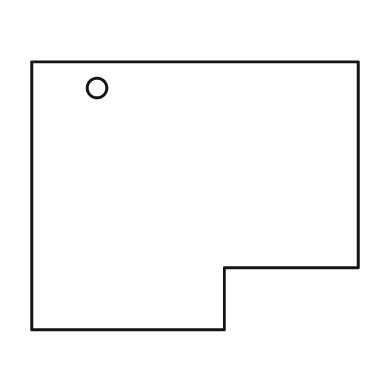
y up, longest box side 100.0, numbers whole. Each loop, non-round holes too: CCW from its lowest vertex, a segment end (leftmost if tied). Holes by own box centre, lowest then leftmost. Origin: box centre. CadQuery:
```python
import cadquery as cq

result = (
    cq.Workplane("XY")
    .moveTo(-50.0, -41.0)
    .lineTo(9.0, -41.0)
    .lineTo(9.0, -22.0)
    .lineTo(50.0, -22.0)
    .lineTo(50.0, 41.0)
    .lineTo(-50.0, 41.0)
    .close()
    .moveTo(-30.0, 33.0)
    .circle(3.0)
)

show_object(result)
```